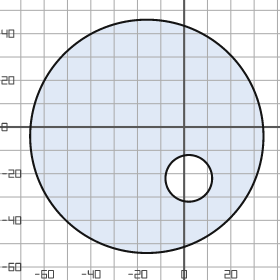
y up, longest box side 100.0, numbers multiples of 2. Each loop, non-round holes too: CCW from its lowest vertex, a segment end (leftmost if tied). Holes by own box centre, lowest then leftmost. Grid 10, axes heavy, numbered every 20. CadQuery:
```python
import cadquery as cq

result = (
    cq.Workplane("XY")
    .moveTo(-16.0, -4.0)
    .circle(50.0)
    .moveTo(2.0, -22.0)
    .circle(10.0)
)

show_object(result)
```